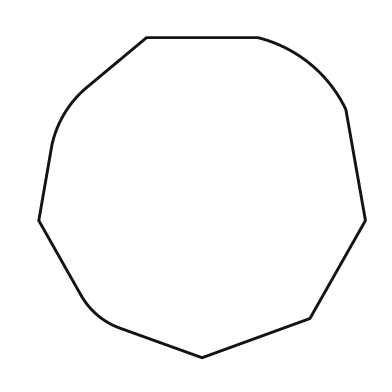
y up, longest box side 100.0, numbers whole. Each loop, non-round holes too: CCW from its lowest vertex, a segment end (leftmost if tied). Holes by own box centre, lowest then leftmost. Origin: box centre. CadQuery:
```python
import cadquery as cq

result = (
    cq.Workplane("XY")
    .moveTo(0.0, -49.0)
    .lineTo(33.0, -37.0)
    .lineTo(50.0, -7.0)
    .lineTo(44.0, 27.0)
    .threePointArc((33.0, 41.0), (17.0, 49.0))
    .lineTo(-17.0, 49.0)
    .lineTo(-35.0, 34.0)
    .threePointArc((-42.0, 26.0), (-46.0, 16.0))
    .lineTo(-50.0, -7.0)
    .lineTo(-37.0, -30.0)
    .threePointArc((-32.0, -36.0), (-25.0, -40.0))
    .close()
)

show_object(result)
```